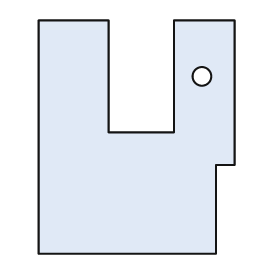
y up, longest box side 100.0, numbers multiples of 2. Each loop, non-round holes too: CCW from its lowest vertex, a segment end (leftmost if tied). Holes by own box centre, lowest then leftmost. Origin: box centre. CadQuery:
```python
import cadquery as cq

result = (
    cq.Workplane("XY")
    .moveTo(-42.0, -50.0)
    .lineTo(34.0, -50.0)
    .lineTo(34.0, -12.0)
    .lineTo(42.0, -12.0)
    .lineTo(42.0, 50.0)
    .lineTo(16.0, 50.0)
    .lineTo(16.0, 2.0)
    .lineTo(-12.0, 2.0)
    .lineTo(-12.0, 50.0)
    .lineTo(-42.0, 50.0)
    .close()
    .moveTo(28.0, 26.0)
    .circle(4.0)
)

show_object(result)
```